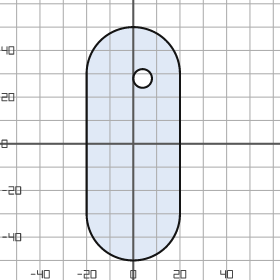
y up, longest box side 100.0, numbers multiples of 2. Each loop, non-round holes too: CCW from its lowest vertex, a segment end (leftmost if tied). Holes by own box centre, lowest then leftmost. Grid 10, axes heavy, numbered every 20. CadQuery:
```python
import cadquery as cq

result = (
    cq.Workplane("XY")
    .moveTo(-20.0, -30.0)
    .threePointArc((0.0, -50.0), (20.0, -30.0))
    .lineTo(20.0, 30.0)
    .threePointArc((0.0, 50.0), (-20.0, 30.0))
    .close()
    .moveTo(4.0, 28.0)
    .circle(4.0)
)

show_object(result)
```